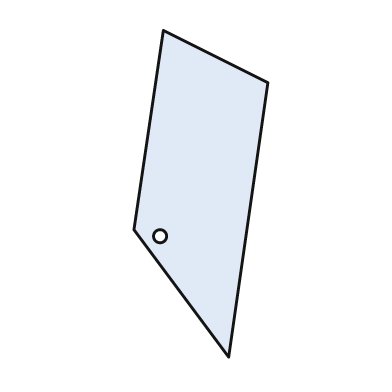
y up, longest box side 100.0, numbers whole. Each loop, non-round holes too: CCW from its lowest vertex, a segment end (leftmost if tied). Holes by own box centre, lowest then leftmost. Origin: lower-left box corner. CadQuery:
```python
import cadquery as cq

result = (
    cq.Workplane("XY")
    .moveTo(29.0, 0.0)
    .lineTo(41.0, 84.0)
    .lineTo(9.0, 100.0)
    .lineTo(0.0, 39.0)
    .close()
    .moveTo(8.0, 37.0)
    .circle(2.0)
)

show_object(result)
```